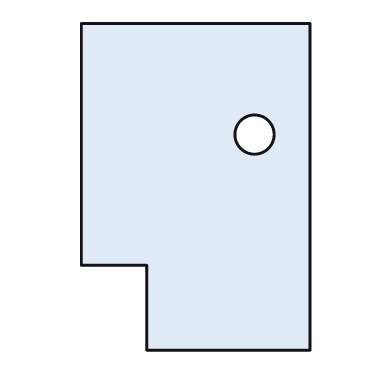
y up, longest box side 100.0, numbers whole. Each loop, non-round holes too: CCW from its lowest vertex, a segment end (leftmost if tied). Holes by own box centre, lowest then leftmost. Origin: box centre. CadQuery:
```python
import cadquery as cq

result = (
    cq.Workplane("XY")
    .moveTo(-15.0, -50.0)
    .lineTo(35.0, -50.0)
    .lineTo(35.0, 50.0)
    .lineTo(-35.0, 50.0)
    .lineTo(-35.0, -24.0)
    .lineTo(-15.0, -24.0)
    .close()
    .moveTo(18.0, 16.0)
    .circle(6.0)
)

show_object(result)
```